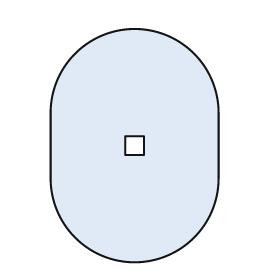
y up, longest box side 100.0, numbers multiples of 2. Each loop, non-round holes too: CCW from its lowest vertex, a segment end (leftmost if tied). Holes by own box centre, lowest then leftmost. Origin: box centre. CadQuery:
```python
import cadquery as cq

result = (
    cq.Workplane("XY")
    .moveTo(-36.0, -14.0)
    .threePointArc((0.0, -50.0), (36.0, -14.0))
    .lineTo(36.0, 14.0)
    .threePointArc((0.0, 50.0), (-36.0, 14.0))
    .close()
    .moveTo(-4.0, -4.0)
    .lineTo(4.0, -4.0)
    .lineTo(4.0, 4.0)
    .lineTo(-4.0, 4.0)
    .close()
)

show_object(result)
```